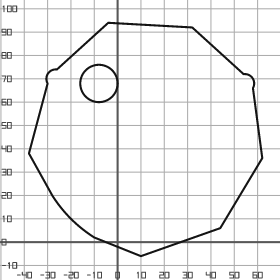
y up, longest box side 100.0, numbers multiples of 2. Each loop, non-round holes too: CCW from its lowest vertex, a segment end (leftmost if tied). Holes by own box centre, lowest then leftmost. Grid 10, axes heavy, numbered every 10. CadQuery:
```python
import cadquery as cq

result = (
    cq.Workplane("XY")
    .moveTo(10.0, -6.0)
    .lineTo(44.0, 6.0)
    .lineTo(62.0, 36.0)
    .lineTo(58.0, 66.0)
    .threePointArc((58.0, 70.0), (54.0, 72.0))
    .lineTo(32.0, 92.0)
    .lineTo(-4.0, 94.0)
    .lineTo(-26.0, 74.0)
    .threePointArc((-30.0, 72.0), (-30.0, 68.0))
    .lineTo(-38.0, 38.0)
    .lineTo(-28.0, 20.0)
    .threePointArc((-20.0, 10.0), (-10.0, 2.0))
    .close()
    .moveTo(-8.0, 68.0)
    .circle(8.0)
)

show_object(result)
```